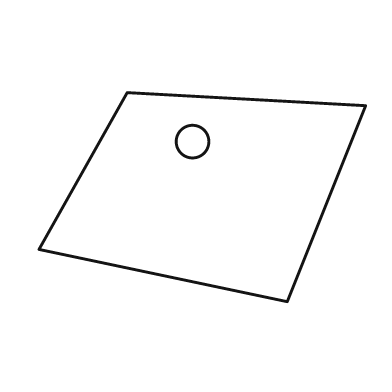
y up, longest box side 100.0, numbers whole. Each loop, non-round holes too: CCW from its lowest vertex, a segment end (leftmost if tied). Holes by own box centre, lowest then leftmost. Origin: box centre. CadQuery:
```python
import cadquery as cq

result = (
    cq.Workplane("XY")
    .moveTo(26.0, -32.0)
    .lineTo(50.0, 28.0)
    .lineTo(-23.0, 32.0)
    .lineTo(-50.0, -16.0)
    .close()
    .moveTo(-3.0, 17.0)
    .circle(5.0)
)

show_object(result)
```